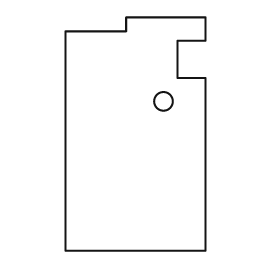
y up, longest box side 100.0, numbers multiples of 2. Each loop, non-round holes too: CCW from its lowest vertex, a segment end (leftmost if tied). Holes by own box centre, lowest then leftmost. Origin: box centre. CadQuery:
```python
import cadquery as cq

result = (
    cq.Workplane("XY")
    .moveTo(-30.0, -50.0)
    .lineTo(30.0, -50.0)
    .lineTo(30.0, 24.0)
    .lineTo(18.0, 24.0)
    .lineTo(18.0, 40.0)
    .lineTo(30.0, 40.0)
    .lineTo(30.0, 50.0)
    .lineTo(-4.0, 50.0)
    .lineTo(-4.0, 44.0)
    .lineTo(-30.0, 44.0)
    .close()
    .moveTo(12.0, 14.0)
    .circle(4.0)
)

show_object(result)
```